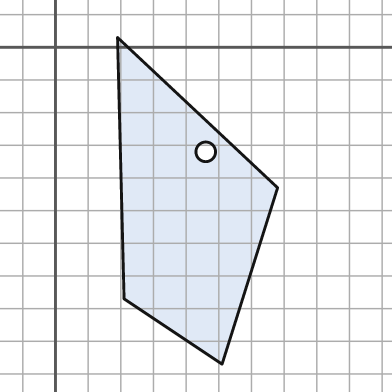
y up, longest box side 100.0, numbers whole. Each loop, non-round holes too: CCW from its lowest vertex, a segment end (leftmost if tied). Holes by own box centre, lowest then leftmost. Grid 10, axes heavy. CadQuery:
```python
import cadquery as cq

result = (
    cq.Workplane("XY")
    .moveTo(51.0, -97.0)
    .lineTo(68.0, -43.0)
    .lineTo(19.0, 3.0)
    .lineTo(21.0, -77.0)
    .close()
    .moveTo(46.0, -32.0)
    .circle(3.0)
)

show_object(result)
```